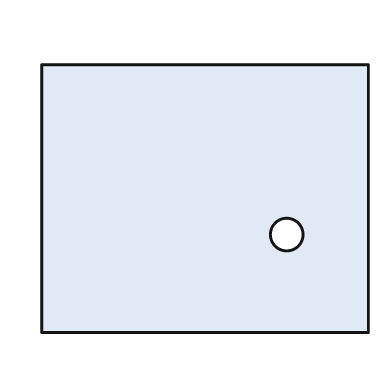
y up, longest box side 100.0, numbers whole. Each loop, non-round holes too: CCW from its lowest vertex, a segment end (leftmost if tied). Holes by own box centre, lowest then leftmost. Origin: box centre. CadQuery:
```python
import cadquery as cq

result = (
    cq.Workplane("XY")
    .moveTo(-50.0, -41.0)
    .lineTo(50.0, -41.0)
    .lineTo(50.0, 41.0)
    .lineTo(-50.0, 41.0)
    .close()
    .moveTo(25.0, -11.0)
    .circle(5.0)
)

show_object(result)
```